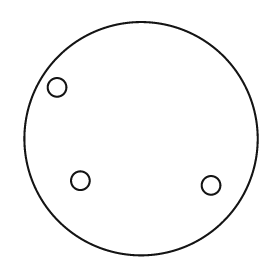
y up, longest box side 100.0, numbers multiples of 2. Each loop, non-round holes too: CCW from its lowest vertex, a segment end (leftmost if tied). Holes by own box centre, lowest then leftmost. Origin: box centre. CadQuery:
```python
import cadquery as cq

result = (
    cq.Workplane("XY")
    .moveTo(0.0, 0.0)
    .circle(50.0)
    .moveTo(30.0, -20.0)
    .circle(4.0)
    .moveTo(-26.0, -18.0)
    .circle(4.0)
    .moveTo(-36.0, 22.0)
    .circle(4.0)
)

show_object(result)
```